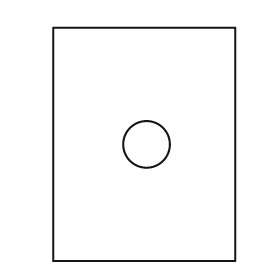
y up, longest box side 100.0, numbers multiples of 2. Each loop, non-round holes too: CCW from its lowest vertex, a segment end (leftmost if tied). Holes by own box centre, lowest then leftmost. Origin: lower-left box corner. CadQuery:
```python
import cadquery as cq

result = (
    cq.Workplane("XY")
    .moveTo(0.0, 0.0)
    .lineTo(78.0, 0.0)
    .lineTo(78.0, 100.0)
    .lineTo(0.0, 100.0)
    .close()
    .moveTo(40.0, 50.0)
    .circle(10.0)
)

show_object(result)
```